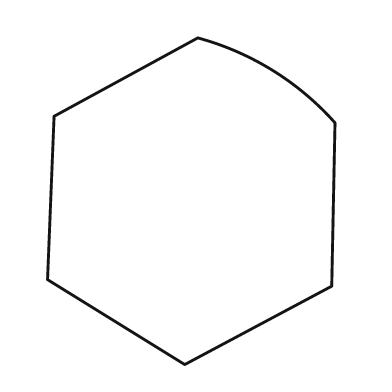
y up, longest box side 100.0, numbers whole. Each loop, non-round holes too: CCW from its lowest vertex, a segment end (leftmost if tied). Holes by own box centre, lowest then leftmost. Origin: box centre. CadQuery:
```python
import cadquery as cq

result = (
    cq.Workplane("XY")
    .moveTo(-2.0, -50.0)
    .lineTo(43.0, -26.0)
    .lineTo(44.0, 24.0)
    .threePointArc((25.0, 40.0), (2.0, 50.0))
    .lineTo(-42.0, 26.0)
    .lineTo(-44.0, -24.0)
    .close()
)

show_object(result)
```